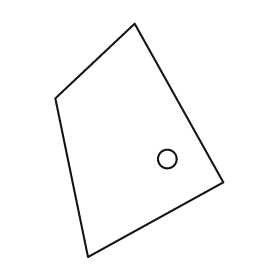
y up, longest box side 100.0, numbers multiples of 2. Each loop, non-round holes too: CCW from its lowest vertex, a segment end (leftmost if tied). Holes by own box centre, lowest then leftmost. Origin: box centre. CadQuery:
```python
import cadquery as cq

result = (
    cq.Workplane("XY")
    .moveTo(-22.0, -50.0)
    .lineTo(36.0, -18.0)
    .lineTo(-2.0, 50.0)
    .lineTo(-36.0, 18.0)
    .close()
    .moveTo(12.0, -8.0)
    .circle(4.0)
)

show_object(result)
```